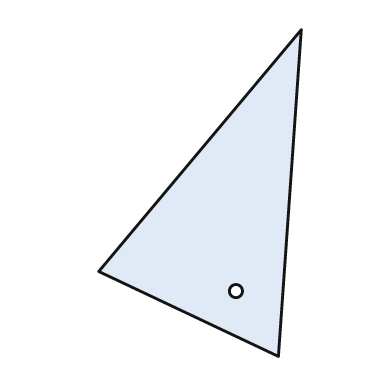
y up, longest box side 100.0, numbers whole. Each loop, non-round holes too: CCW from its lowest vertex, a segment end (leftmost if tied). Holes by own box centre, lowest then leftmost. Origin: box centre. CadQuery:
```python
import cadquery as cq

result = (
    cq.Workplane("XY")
    .moveTo(24.0, -50.0)
    .lineTo(31.0, 50.0)
    .lineTo(-31.0, -24.0)
    .close()
    .moveTo(11.0, -30.0)
    .circle(2.0)
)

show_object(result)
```